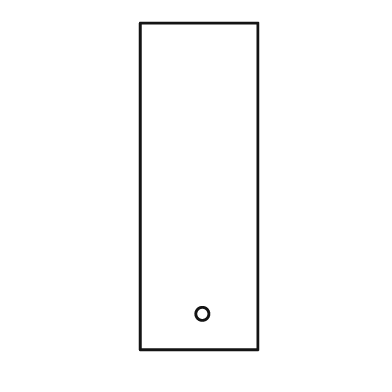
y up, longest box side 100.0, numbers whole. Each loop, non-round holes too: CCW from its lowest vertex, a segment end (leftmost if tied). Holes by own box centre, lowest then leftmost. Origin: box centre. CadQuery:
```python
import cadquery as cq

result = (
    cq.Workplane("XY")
    .moveTo(-18.0, -50.0)
    .lineTo(18.0, -50.0)
    .lineTo(18.0, 50.0)
    .lineTo(-18.0, 50.0)
    .close()
    .moveTo(1.0, -39.0)
    .circle(2.0)
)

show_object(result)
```